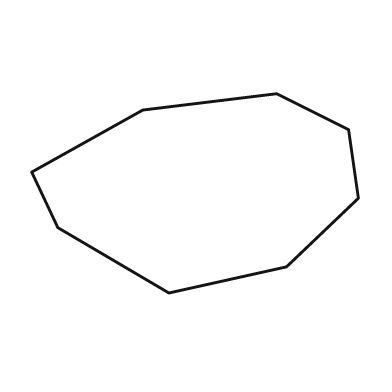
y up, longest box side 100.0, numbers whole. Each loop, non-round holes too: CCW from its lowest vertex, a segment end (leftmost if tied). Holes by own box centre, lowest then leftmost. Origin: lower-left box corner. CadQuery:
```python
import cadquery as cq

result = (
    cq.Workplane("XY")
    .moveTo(42.0, 0.0)
    .lineTo(78.0, 8.0)
    .lineTo(100.0, 29.0)
    .lineTo(97.0, 50.0)
    .lineTo(75.0, 61.0)
    .lineTo(34.0, 56.0)
    .lineTo(0.0, 37.0)
    .lineTo(8.0, 20.0)
    .close()
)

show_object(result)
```